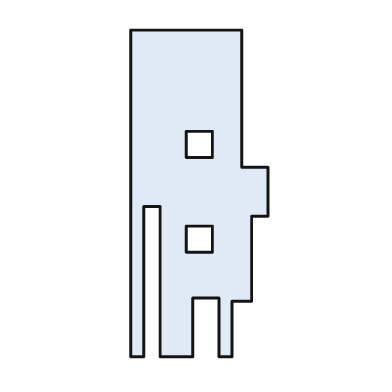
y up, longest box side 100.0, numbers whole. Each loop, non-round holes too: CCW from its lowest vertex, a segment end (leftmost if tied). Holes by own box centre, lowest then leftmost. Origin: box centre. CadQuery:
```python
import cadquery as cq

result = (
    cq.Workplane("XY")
    .moveTo(-21.0, -50.0)
    .lineTo(-17.0, -50.0)
    .lineTo(-17.0, -4.0)
    .lineTo(-12.0, -4.0)
    .lineTo(-12.0, -50.0)
    .lineTo(-2.0, -50.0)
    .lineTo(-2.0, -32.0)
    .lineTo(6.0, -32.0)
    .lineTo(6.0, -50.0)
    .lineTo(10.0, -50.0)
    .lineTo(10.0, -33.0)
    .lineTo(16.0, -33.0)
    .lineTo(16.0, -7.0)
    .lineTo(21.0, -7.0)
    .lineTo(21.0, 8.0)
    .lineTo(13.0, 8.0)
    .lineTo(13.0, 50.0)
    .lineTo(-21.0, 50.0)
    .close()
    .moveTo(-4.0, -18.0)
    .lineTo(4.0, -18.0)
    .lineTo(4.0, -10.0)
    .lineTo(-4.0, -10.0)
    .close()
    .moveTo(-4.0, 11.0)
    .lineTo(4.0, 11.0)
    .lineTo(4.0, 19.0)
    .lineTo(-4.0, 19.0)
    .close()
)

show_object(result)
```